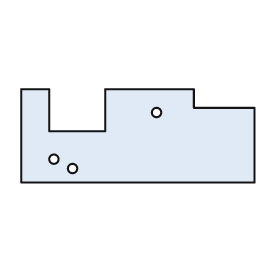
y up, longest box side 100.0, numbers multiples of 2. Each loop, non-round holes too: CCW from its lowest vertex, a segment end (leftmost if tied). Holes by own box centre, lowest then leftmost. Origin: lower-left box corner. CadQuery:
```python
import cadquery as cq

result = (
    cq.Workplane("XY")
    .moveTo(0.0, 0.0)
    .lineTo(100.0, 0.0)
    .lineTo(100.0, 32.0)
    .lineTo(74.0, 32.0)
    .lineTo(74.0, 40.0)
    .lineTo(36.0, 40.0)
    .lineTo(36.0, 22.0)
    .lineTo(12.0, 22.0)
    .lineTo(12.0, 40.0)
    .lineTo(0.0, 40.0)
    .close()
    .moveTo(22.0, 6.0)
    .circle(2.0)
    .moveTo(14.0, 10.0)
    .circle(2.0)
    .moveTo(58.0, 30.0)
    .circle(2.0)
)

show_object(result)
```